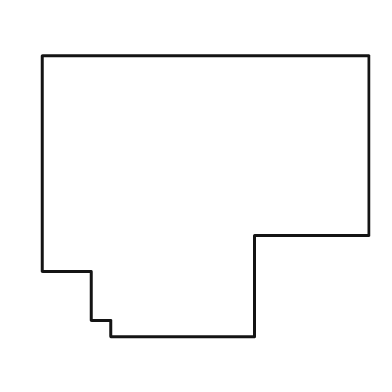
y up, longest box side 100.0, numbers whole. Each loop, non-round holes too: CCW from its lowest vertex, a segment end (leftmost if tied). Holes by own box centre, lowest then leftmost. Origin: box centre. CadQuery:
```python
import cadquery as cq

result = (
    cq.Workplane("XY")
    .moveTo(-29.0, -43.0)
    .lineTo(15.0, -43.0)
    .lineTo(15.0, -12.0)
    .lineTo(50.0, -12.0)
    .lineTo(50.0, 43.0)
    .lineTo(-50.0, 43.0)
    .lineTo(-50.0, -23.0)
    .lineTo(-35.0, -23.0)
    .lineTo(-35.0, -38.0)
    .lineTo(-29.0, -38.0)
    .close()
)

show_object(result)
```